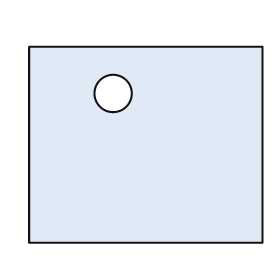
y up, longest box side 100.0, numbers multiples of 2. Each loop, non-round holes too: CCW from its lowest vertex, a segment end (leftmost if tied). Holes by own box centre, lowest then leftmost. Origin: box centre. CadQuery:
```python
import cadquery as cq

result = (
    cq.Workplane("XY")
    .moveTo(-50.0, -42.0)
    .lineTo(50.0, -42.0)
    .lineTo(50.0, 42.0)
    .lineTo(-50.0, 42.0)
    .close()
    .moveTo(-14.0, 22.0)
    .circle(8.0)
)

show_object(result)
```